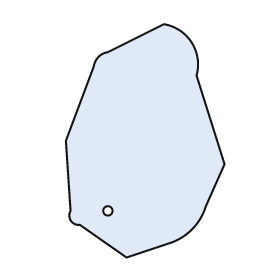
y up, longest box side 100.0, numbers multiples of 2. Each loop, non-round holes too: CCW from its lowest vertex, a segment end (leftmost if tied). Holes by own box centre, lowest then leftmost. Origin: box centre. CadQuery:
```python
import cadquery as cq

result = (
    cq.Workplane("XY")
    .moveTo(-8.0, -50.0)
    .lineTo(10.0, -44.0)
    .threePointArc((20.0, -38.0), (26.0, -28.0))
    .lineTo(34.0, -10.0)
    .lineTo(22.0, 28.0)
    .threePointArc((20.0, 42.0), (8.0, 50.0))
    .lineTo(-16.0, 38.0)
    .threePointArc((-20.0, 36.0), (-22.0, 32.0))
    .lineTo(-34.0, 0.0)
    .lineTo(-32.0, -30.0)
    .threePointArc((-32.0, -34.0), (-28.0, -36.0))
    .close()
    .moveTo(-16.0, -30.0)
    .circle(2.0)
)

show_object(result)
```